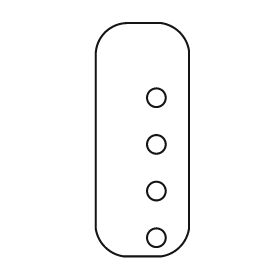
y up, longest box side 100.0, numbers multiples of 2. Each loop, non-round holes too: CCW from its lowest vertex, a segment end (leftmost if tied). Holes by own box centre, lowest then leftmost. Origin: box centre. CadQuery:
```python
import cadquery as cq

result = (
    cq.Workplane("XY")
    .moveTo(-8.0, -50.0)
    .lineTo(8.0, -50.0)
    .threePointArc((16.0, -46.0), (20.0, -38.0))
    .lineTo(20.0, 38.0)
    .threePointArc((16.0, 46.0), (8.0, 50.0))
    .lineTo(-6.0, 50.0)
    .threePointArc((-16.0, 46.0), (-20.0, 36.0))
    .lineTo(-20.0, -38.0)
    .threePointArc((-16.0, -46.0), (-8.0, -50.0))
    .close()
    .moveTo(6.0, -42.0)
    .circle(4.0)
    .moveTo(6.0, -22.0)
    .circle(4.0)
    .moveTo(6.0, -2.0)
    .circle(4.0)
    .moveTo(6.0, 18.0)
    .circle(4.0)
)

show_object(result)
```